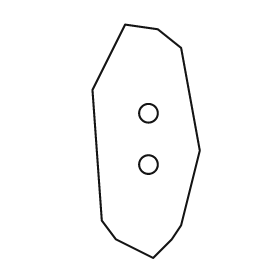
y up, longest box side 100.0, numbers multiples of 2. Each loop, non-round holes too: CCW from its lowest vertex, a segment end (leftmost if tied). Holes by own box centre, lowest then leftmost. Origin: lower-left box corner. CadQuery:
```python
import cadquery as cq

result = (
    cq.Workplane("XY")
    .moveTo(26.0, 0.0)
    .lineTo(34.0, 8.0)
    .lineTo(38.0, 14.0)
    .lineTo(46.0, 46.0)
    .lineTo(38.0, 90.0)
    .lineTo(28.0, 98.0)
    .lineTo(14.0, 100.0)
    .lineTo(0.0, 72.0)
    .lineTo(4.0, 16.0)
    .lineTo(10.0, 8.0)
    .close()
    .moveTo(24.0, 40.0)
    .circle(4.0)
    .moveTo(24.0, 62.0)
    .circle(4.0)
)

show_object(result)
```